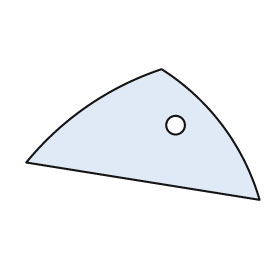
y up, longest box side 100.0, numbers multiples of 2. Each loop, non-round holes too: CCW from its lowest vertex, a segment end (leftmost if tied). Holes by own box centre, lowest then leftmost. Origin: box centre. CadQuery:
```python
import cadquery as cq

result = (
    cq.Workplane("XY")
    .moveTo(50.0, -28.0)
    .threePointArc((34.0, 4.0), (8.0, 28.0))
    .threePointArc((-24.0, 12.0), (-50.0, -12.0))
    .close()
    .moveTo(14.0, 4.0)
    .circle(4.0)
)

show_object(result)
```